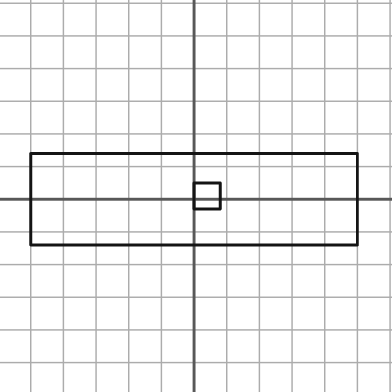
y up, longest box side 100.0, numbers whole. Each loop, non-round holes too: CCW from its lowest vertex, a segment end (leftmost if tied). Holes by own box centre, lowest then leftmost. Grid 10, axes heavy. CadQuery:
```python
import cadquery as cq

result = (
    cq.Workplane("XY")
    .moveTo(-50.0, -14.0)
    .lineTo(50.0, -14.0)
    .lineTo(50.0, 14.0)
    .lineTo(-50.0, 14.0)
    .close()
    .moveTo(0.0, -3.0)
    .lineTo(8.0, -3.0)
    .lineTo(8.0, 5.0)
    .lineTo(0.0, 5.0)
    .close()
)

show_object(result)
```